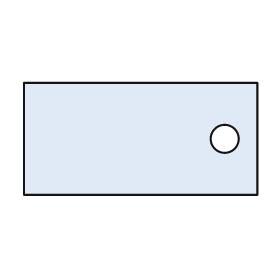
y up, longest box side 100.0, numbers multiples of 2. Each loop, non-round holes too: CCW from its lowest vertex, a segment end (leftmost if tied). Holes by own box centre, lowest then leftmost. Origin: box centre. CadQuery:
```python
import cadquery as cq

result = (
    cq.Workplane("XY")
    .moveTo(-50.0, -24.0)
    .lineTo(50.0, -24.0)
    .lineTo(50.0, 24.0)
    .lineTo(-50.0, 24.0)
    .close()
    .moveTo(36.0, 0.0)
    .circle(6.0)
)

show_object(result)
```